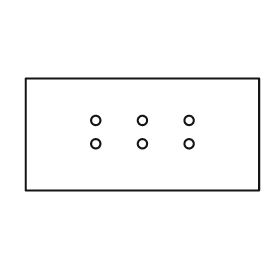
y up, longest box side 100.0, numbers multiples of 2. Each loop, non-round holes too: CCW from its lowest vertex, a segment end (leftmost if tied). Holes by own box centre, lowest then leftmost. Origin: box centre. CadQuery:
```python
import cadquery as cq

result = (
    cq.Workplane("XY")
    .moveTo(-50.0, -24.0)
    .lineTo(50.0, -24.0)
    .lineTo(50.0, 24.0)
    .lineTo(-50.0, 24.0)
    .close()
    .moveTo(-20.0, -4.0)
    .circle(2.0)
    .moveTo(0.0, -4.0)
    .circle(2.0)
    .moveTo(20.0, -4.0)
    .circle(2.0)
    .moveTo(-20.0, 6.0)
    .circle(2.0)
    .moveTo(0.0, 6.0)
    .circle(2.0)
    .moveTo(20.0, 6.0)
    .circle(2.0)
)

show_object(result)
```